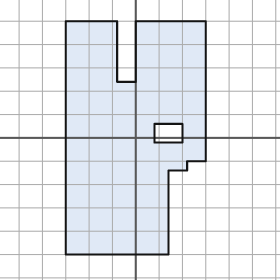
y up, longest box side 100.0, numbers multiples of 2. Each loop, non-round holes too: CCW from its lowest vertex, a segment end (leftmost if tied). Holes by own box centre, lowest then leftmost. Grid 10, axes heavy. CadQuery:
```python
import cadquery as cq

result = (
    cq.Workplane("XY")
    .moveTo(-30.0, -50.0)
    .lineTo(14.0, -50.0)
    .lineTo(14.0, -14.0)
    .lineTo(22.0, -14.0)
    .lineTo(22.0, -10.0)
    .lineTo(30.0, -10.0)
    .lineTo(30.0, 50.0)
    .lineTo(0.0, 50.0)
    .lineTo(0.0, 24.0)
    .lineTo(-8.0, 24.0)
    .lineTo(-8.0, 50.0)
    .lineTo(-30.0, 50.0)
    .close()
    .moveTo(8.0, -2.0)
    .lineTo(20.0, -2.0)
    .lineTo(20.0, 6.0)
    .lineTo(8.0, 6.0)
    .close()
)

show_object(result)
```